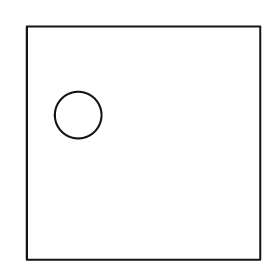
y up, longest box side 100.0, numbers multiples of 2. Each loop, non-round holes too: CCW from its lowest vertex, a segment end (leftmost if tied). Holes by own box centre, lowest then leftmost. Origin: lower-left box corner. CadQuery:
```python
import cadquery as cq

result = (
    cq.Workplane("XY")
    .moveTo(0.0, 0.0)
    .lineTo(100.0, 0.0)
    .lineTo(100.0, 100.0)
    .lineTo(0.0, 100.0)
    .close()
    .moveTo(22.0, 62.0)
    .circle(10.0)
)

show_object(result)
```